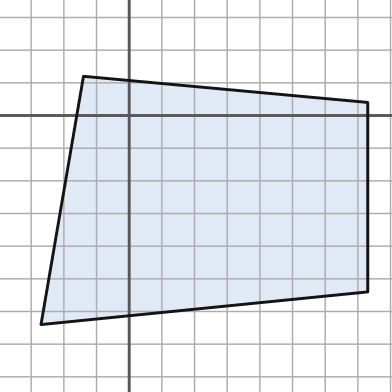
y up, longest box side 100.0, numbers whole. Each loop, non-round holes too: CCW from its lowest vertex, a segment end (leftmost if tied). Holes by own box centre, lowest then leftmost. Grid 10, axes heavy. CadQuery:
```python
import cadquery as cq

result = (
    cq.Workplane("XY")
    .moveTo(-27.0, -64.0)
    .lineTo(73.0, -54.0)
    .lineTo(73.0, 4.0)
    .lineTo(-14.0, 12.0)
    .close()
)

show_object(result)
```